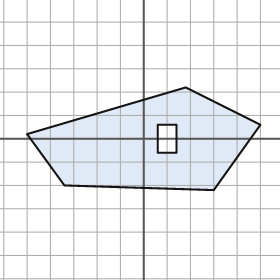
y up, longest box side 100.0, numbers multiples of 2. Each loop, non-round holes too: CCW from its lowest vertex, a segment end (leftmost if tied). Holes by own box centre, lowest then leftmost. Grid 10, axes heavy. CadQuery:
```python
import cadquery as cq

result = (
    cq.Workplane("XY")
    .moveTo(30.0, -22.0)
    .lineTo(50.0, 6.0)
    .lineTo(18.0, 22.0)
    .lineTo(-50.0, 2.0)
    .lineTo(-34.0, -20.0)
    .close()
    .moveTo(6.0, -6.0)
    .lineTo(14.0, -6.0)
    .lineTo(14.0, 6.0)
    .lineTo(6.0, 6.0)
    .close()
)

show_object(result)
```